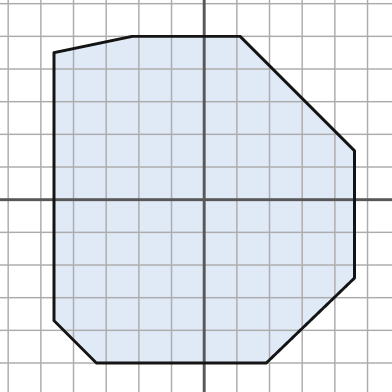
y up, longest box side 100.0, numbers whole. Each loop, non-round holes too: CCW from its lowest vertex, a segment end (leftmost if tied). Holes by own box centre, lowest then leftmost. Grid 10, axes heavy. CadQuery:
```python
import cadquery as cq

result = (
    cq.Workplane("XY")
    .moveTo(-33.0, -50.0)
    .lineTo(19.0, -50.0)
    .lineTo(46.0, -24.0)
    .lineTo(46.0, 15.0)
    .lineTo(11.0, 50.0)
    .lineTo(-22.0, 50.0)
    .lineTo(-46.0, 45.0)
    .lineTo(-46.0, -37.0)
    .close()
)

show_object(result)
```